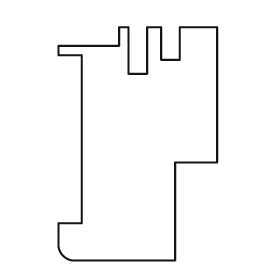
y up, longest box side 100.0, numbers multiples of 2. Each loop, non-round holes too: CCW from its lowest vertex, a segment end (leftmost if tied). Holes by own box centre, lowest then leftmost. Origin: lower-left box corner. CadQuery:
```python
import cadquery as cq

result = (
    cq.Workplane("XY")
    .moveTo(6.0, 0.0)
    .lineTo(50.0, 0.0)
    .lineTo(50.0, 42.0)
    .lineTo(68.0, 42.0)
    .lineTo(68.0, 100.0)
    .lineTo(52.0, 100.0)
    .lineTo(52.0, 86.0)
    .lineTo(44.0, 86.0)
    .lineTo(44.0, 100.0)
    .lineTo(38.0, 100.0)
    .lineTo(38.0, 80.0)
    .lineTo(30.0, 80.0)
    .lineTo(30.0, 100.0)
    .lineTo(26.0, 100.0)
    .lineTo(26.0, 92.0)
    .lineTo(0.0, 92.0)
    .lineTo(0.0, 88.0)
    .lineTo(10.0, 88.0)
    .lineTo(10.0, 16.0)
    .lineTo(0.0, 16.0)
    .lineTo(0.0, 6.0)
    .threePointArc((2.0, 2.0), (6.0, 0.0))
    .close()
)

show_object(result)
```